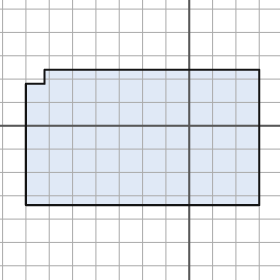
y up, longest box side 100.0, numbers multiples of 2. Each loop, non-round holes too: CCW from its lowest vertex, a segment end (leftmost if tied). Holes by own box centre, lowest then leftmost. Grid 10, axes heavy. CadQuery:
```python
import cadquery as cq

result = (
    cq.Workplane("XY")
    .moveTo(-70.0, -34.0)
    .lineTo(30.0, -34.0)
    .lineTo(30.0, 24.0)
    .lineTo(-62.0, 24.0)
    .lineTo(-62.0, 18.0)
    .lineTo(-70.0, 18.0)
    .close()
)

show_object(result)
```